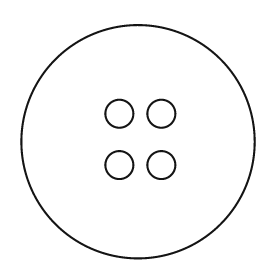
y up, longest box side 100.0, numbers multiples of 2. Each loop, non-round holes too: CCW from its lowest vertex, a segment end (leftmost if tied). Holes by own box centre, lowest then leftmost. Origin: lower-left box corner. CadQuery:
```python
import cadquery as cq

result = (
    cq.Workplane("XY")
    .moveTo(50.0, 50.0)
    .circle(50.0)
    .moveTo(42.0, 40.0)
    .circle(6.0)
    .moveTo(60.0, 40.0)
    .circle(6.0)
    .moveTo(42.0, 62.0)
    .circle(6.0)
    .moveTo(60.0, 62.0)
    .circle(6.0)
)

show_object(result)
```